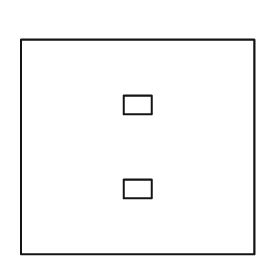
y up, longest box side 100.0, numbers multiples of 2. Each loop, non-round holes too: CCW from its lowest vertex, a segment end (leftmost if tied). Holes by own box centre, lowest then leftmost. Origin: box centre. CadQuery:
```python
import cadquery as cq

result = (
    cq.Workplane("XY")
    .moveTo(-50.0, -46.0)
    .lineTo(50.0, -46.0)
    .lineTo(50.0, 46.0)
    .lineTo(-50.0, 46.0)
    .close()
    .moveTo(-6.0, -22.0)
    .lineTo(6.0, -22.0)
    .lineTo(6.0, -14.0)
    .lineTo(-6.0, -14.0)
    .close()
    .moveTo(-6.0, 14.0)
    .lineTo(6.0, 14.0)
    .lineTo(6.0, 22.0)
    .lineTo(-6.0, 22.0)
    .close()
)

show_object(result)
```